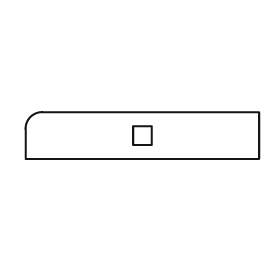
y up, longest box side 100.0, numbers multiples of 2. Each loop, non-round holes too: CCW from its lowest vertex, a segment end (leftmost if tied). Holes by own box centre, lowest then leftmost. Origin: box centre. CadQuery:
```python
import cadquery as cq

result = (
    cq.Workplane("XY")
    .moveTo(-50.0, -10.0)
    .lineTo(50.0, -10.0)
    .lineTo(50.0, 10.0)
    .lineTo(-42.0, 10.0)
    .threePointArc((-48.0, 8.0), (-50.0, 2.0))
    .close()
    .moveTo(-4.0, -4.0)
    .lineTo(4.0, -4.0)
    .lineTo(4.0, 4.0)
    .lineTo(-4.0, 4.0)
    .close()
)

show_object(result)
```